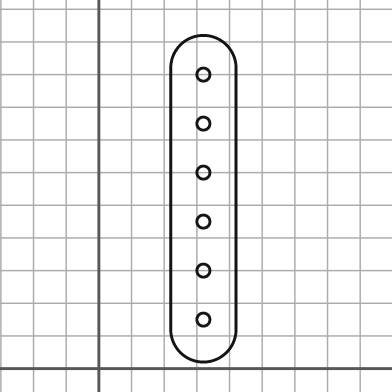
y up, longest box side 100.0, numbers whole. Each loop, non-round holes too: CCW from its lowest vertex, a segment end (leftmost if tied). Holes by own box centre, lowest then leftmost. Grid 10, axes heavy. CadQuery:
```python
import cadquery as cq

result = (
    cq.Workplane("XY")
    .moveTo(22.0, 12.0)
    .threePointArc((32.0, 2.0), (42.0, 12.0))
    .lineTo(42.0, 92.0)
    .threePointArc((32.0, 102.0), (22.0, 92.0))
    .close()
    .moveTo(32.0, 15.0)
    .circle(2.0)
    .moveTo(32.0, 30.0)
    .circle(2.0)
    .moveTo(32.0, 45.0)
    .circle(2.0)
    .moveTo(32.0, 60.0)
    .circle(2.0)
    .moveTo(32.0, 75.0)
    .circle(2.0)
    .moveTo(32.0, 90.0)
    .circle(2.0)
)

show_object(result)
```